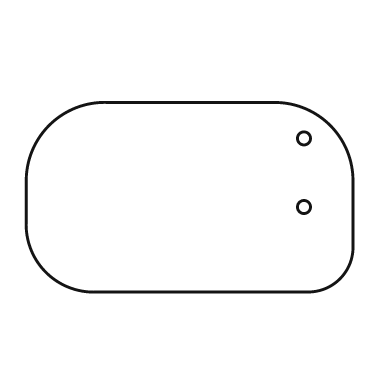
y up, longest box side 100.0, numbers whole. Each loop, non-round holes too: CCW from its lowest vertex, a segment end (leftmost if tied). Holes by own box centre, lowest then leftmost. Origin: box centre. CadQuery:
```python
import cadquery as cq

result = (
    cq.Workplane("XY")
    .moveTo(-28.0, -29.0)
    .lineTo(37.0, -29.0)
    .threePointArc((46.0, -25.0), (50.0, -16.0))
    .lineTo(50.0, 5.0)
    .threePointArc((43.0, 22.0), (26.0, 29.0))
    .lineTo(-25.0, 29.0)
    .threePointArc((-43.0, 22.0), (-50.0, 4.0))
    .lineTo(-50.0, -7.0)
    .threePointArc((-44.0, -23.0), (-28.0, -29.0))
    .close()
    .moveTo(35.0, -3.0)
    .circle(2.0)
    .moveTo(35.0, 18.0)
    .circle(2.0)
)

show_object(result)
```